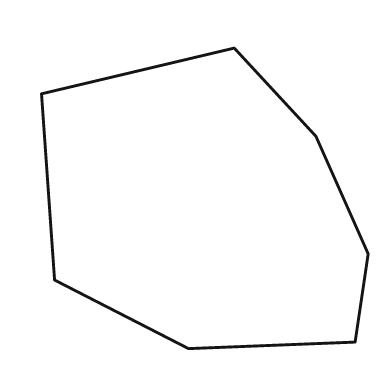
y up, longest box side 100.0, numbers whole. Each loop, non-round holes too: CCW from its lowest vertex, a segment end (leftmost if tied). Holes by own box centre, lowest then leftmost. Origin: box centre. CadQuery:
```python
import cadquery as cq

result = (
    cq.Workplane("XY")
    .moveTo(-5.0, -46.0)
    .lineTo(46.0, -44.0)
    .lineTo(50.0, -17.0)
    .lineTo(34.0, 19.0)
    .lineTo(9.0, 46.0)
    .lineTo(-50.0, 32.0)
    .lineTo(-46.0, -25.0)
    .close()
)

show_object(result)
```